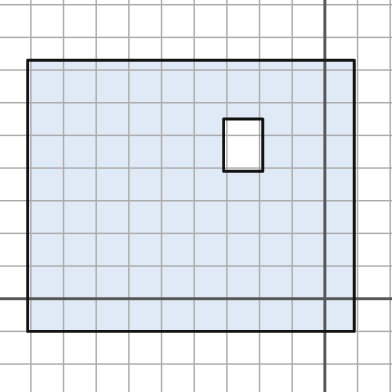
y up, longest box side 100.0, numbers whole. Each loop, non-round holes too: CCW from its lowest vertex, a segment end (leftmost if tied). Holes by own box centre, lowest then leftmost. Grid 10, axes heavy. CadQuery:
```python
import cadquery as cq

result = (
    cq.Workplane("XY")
    .moveTo(-91.0, -10.0)
    .lineTo(9.0, -10.0)
    .lineTo(9.0, 73.0)
    .lineTo(-91.0, 73.0)
    .close()
    .moveTo(-31.0, 39.0)
    .lineTo(-19.0, 39.0)
    .lineTo(-19.0, 55.0)
    .lineTo(-31.0, 55.0)
    .close()
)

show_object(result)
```